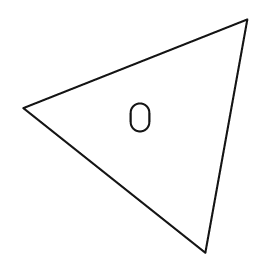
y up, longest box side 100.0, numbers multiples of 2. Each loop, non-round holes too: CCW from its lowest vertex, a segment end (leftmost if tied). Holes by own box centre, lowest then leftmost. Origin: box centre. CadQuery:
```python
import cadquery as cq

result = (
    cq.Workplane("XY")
    .moveTo(30.0, -50.0)
    .lineTo(48.0, 50.0)
    .lineTo(-48.0, 12.0)
    .close()
    .moveTo(-2.0, 6.0)
    .threePointArc((2.0, 2.0), (6.0, 6.0))
    .lineTo(6.0, 10.0)
    .threePointArc((2.0, 14.0), (-2.0, 10.0))
    .close()
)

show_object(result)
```